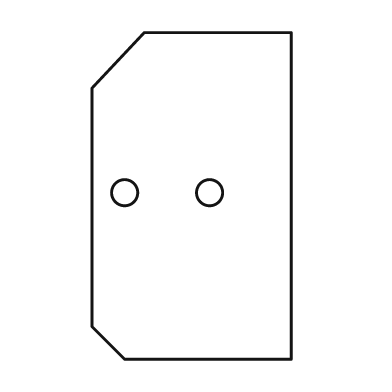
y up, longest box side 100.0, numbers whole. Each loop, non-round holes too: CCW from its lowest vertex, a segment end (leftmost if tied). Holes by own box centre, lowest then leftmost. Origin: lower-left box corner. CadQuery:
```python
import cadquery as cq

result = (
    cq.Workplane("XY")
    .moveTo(10.0, 0.0)
    .lineTo(61.0, 0.0)
    .lineTo(61.0, 100.0)
    .lineTo(16.0, 100.0)
    .lineTo(0.0, 83.0)
    .lineTo(0.0, 10.0)
    .close()
    .moveTo(10.0, 51.0)
    .circle(4.0)
    .moveTo(36.0, 51.0)
    .circle(4.0)
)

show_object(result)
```